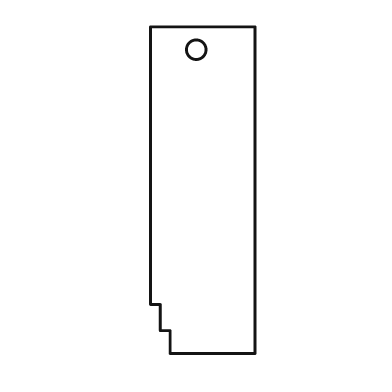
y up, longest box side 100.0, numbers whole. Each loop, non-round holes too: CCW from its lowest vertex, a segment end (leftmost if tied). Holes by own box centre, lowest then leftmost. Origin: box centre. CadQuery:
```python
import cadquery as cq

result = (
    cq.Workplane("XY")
    .moveTo(-10.0, -50.0)
    .lineTo(16.0, -50.0)
    .lineTo(16.0, 50.0)
    .lineTo(-16.0, 50.0)
    .lineTo(-16.0, -35.0)
    .lineTo(-13.0, -35.0)
    .lineTo(-13.0, -43.0)
    .lineTo(-10.0, -43.0)
    .close()
    .moveTo(-2.0, 43.0)
    .circle(3.0)
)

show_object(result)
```